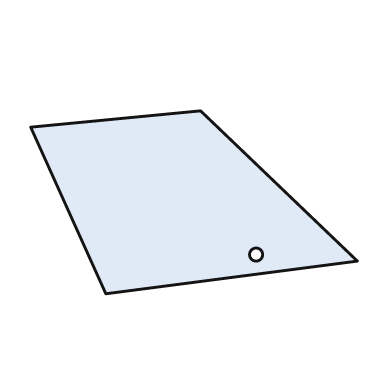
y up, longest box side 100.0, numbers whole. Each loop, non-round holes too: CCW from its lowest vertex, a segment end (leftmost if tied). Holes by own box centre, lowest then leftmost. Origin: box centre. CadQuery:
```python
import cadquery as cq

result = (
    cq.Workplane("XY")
    .moveTo(-27.0, -28.0)
    .lineTo(50.0, -18.0)
    .lineTo(2.0, 28.0)
    .lineTo(-50.0, 23.0)
    .close()
    .moveTo(19.0, -16.0)
    .circle(2.0)
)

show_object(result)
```